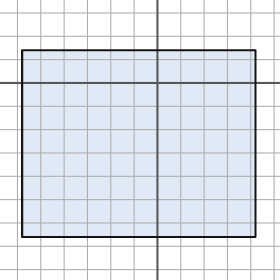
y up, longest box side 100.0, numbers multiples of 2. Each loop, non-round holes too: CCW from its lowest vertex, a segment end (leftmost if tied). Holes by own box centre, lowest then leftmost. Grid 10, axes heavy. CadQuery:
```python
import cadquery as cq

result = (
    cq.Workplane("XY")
    .moveTo(-58.0, -66.0)
    .lineTo(42.0, -66.0)
    .lineTo(42.0, 14.0)
    .lineTo(-58.0, 14.0)
    .close()
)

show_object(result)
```